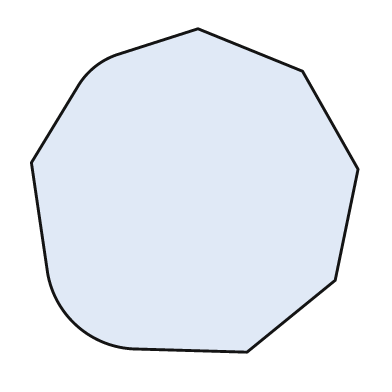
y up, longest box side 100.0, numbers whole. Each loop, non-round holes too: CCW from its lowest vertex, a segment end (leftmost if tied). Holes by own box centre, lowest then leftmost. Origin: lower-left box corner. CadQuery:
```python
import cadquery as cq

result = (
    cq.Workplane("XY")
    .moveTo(66.0, 0.0)
    .lineTo(93.0, 22.0)
    .lineTo(100.0, 56.0)
    .lineTo(83.0, 86.0)
    .lineTo(51.0, 99.0)
    .lineTo(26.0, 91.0)
    .threePointArc((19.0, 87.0), (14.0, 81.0))
    .lineTo(0.0, 58.0)
    .lineTo(5.0, 24.0)
    .threePointArc((14.0, 8.0), (31.0, 1.0))
    .close()
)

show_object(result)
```